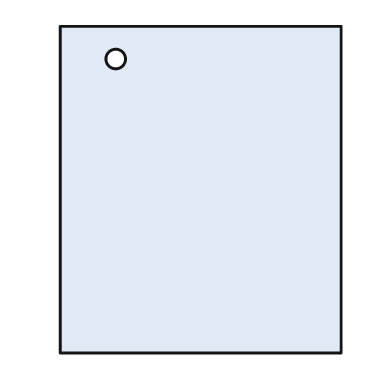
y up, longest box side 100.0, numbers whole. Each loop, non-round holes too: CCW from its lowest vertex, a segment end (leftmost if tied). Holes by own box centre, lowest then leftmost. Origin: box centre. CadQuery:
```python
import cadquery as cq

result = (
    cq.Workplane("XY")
    .moveTo(-43.0, -50.0)
    .lineTo(43.0, -50.0)
    .lineTo(43.0, 50.0)
    .lineTo(-43.0, 50.0)
    .close()
    .moveTo(-26.0, 40.0)
    .circle(3.0)
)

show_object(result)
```